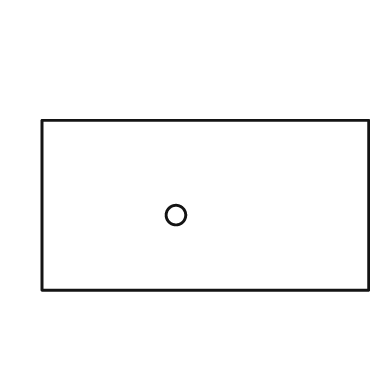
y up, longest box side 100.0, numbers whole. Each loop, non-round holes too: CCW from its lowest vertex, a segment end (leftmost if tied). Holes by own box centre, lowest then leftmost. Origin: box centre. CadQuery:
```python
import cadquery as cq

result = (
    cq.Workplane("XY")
    .moveTo(-50.0, -26.0)
    .lineTo(50.0, -26.0)
    .lineTo(50.0, 26.0)
    .lineTo(-50.0, 26.0)
    .close()
    .moveTo(-9.0, -3.0)
    .circle(3.0)
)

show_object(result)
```